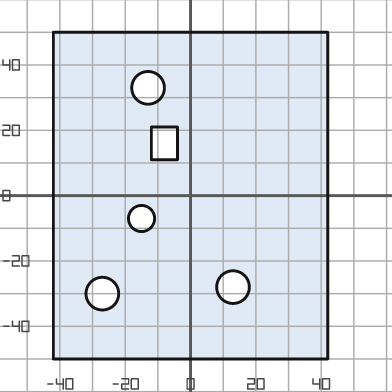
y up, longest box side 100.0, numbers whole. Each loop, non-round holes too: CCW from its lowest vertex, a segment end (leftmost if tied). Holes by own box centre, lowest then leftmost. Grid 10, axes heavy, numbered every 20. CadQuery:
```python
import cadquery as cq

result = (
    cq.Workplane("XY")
    .moveTo(-42.0, -50.0)
    .lineTo(42.0, -50.0)
    .lineTo(42.0, 50.0)
    .lineTo(-42.0, 50.0)
    .close()
    .moveTo(-27.0, -30.0)
    .circle(5.0)
    .moveTo(13.0, -28.0)
    .circle(5.0)
    .moveTo(-15.0, -7.0)
    .circle(4.0)
    .moveTo(-12.0, 11.0)
    .lineTo(-4.0, 11.0)
    .lineTo(-4.0, 21.0)
    .lineTo(-12.0, 21.0)
    .close()
    .moveTo(-13.0, 33.0)
    .circle(5.0)
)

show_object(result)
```